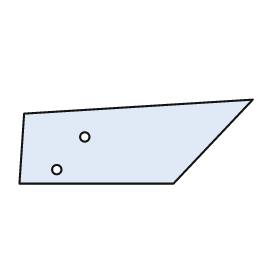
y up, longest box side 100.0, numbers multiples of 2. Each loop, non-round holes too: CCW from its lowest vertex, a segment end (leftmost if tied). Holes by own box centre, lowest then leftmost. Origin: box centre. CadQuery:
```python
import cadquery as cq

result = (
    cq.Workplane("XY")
    .moveTo(-50.0, -18.0)
    .lineTo(16.0, -18.0)
    .lineTo(50.0, 18.0)
    .lineTo(-48.0, 12.0)
    .close()
    .moveTo(-34.0, -12.0)
    .circle(2.0)
    .moveTo(-22.0, 2.0)
    .circle(2.0)
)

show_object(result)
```